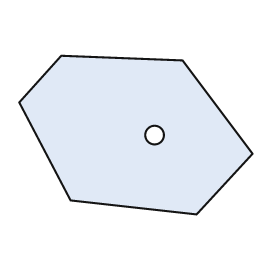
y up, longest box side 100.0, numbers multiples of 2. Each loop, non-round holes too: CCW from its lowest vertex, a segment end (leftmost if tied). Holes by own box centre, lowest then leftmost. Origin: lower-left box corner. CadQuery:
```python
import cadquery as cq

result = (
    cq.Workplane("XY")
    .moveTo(76.0, 0.0)
    .lineTo(100.0, 26.0)
    .lineTo(70.0, 66.0)
    .lineTo(18.0, 68.0)
    .lineTo(0.0, 48.0)
    .lineTo(22.0, 6.0)
    .close()
    .moveTo(58.0, 34.0)
    .circle(4.0)
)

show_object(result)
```